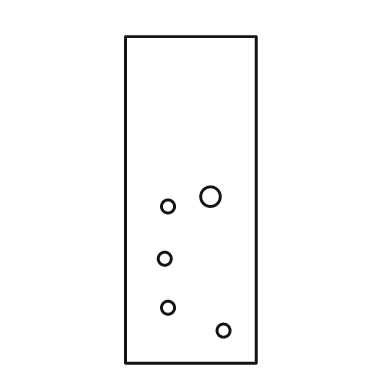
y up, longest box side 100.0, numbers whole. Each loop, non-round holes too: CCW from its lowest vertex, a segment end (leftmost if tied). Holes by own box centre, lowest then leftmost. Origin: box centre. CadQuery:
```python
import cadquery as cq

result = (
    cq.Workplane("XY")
    .moveTo(-20.0, -50.0)
    .lineTo(20.0, -50.0)
    .lineTo(20.0, 50.0)
    .lineTo(-20.0, 50.0)
    .close()
    .moveTo(10.0, -40.0)
    .circle(2.0)
    .moveTo(-7.0, -33.0)
    .circle(2.0)
    .moveTo(-8.0, -18.0)
    .circle(2.0)
    .moveTo(-7.0, -2.0)
    .circle(2.0)
    .moveTo(6.0, 1.0)
    .circle(3.0)
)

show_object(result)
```